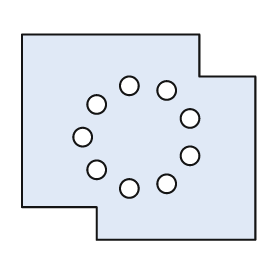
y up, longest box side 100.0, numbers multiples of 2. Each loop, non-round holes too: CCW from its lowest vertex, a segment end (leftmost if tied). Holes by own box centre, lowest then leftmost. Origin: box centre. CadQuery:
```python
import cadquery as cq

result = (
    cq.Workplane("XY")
    .moveTo(-18.0, -44.0)
    .lineTo(50.0, -44.0)
    .lineTo(50.0, 26.0)
    .lineTo(26.0, 26.0)
    .lineTo(26.0, 44.0)
    .lineTo(-50.0, 44.0)
    .lineTo(-50.0, -30.0)
    .lineTo(-18.0, -30.0)
    .close()
    .moveTo(-4.0, -22.0)
    .circle(4.0)
    .moveTo(12.0, -20.0)
    .circle(4.0)
    .moveTo(-18.0, -14.0)
    .circle(4.0)
    .moveTo(22.0, -8.0)
    .circle(4.0)
    .moveTo(-24.0, 0.0)
    .circle(4.0)
    .moveTo(22.0, 8.0)
    .circle(4.0)
    .moveTo(-18.0, 14.0)
    .circle(4.0)
    .moveTo(12.0, 20.0)
    .circle(4.0)
    .moveTo(-4.0, 22.0)
    .circle(4.0)
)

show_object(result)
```